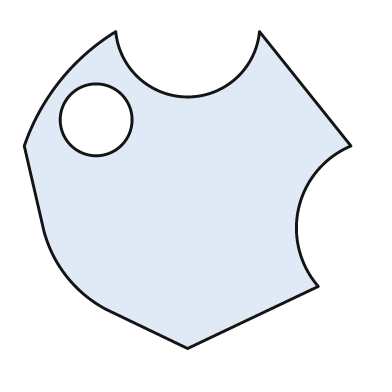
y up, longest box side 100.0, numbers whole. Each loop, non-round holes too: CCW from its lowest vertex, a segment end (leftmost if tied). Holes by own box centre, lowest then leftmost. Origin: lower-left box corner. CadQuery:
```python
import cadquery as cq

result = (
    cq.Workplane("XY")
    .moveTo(50.0, 0.0)
    .lineTo(90.0, 19.0)
    .threePointArc((84.0, 43.0), (100.0, 62.0))
    .lineTo(72.0, 97.0)
    .threePointArc((50.0, 77.0), (28.0, 97.0))
    .threePointArc((11.0, 82.0), (0.0, 62.0))
    .lineTo(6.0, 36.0)
    .threePointArc((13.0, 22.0), (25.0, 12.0))
    .close()
    .moveTo(22.0, 70.0)
    .circle(11.0)
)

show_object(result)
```